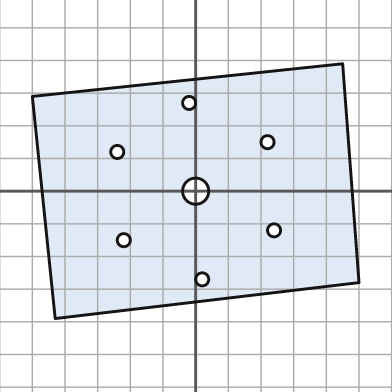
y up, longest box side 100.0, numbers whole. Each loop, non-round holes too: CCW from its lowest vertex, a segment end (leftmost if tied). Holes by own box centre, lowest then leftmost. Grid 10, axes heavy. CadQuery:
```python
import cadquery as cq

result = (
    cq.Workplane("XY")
    .moveTo(-43.0, -39.0)
    .lineTo(50.0, -28.0)
    .lineTo(45.0, 39.0)
    .lineTo(-50.0, 29.0)
    .close()
    .moveTo(2.0, -27.0)
    .circle(2.0)
    .moveTo(-22.0, -15.0)
    .circle(2.0)
    .moveTo(24.0, -12.0)
    .circle(2.0)
    .moveTo(0.0, 0.0)
    .circle(4.0)
    .moveTo(-24.0, 12.0)
    .circle(2.0)
    .moveTo(22.0, 15.0)
    .circle(2.0)
    .moveTo(-2.0, 27.0)
    .circle(2.0)
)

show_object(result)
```